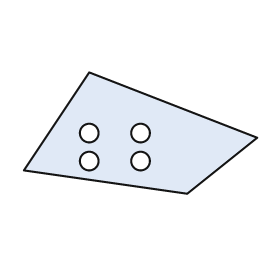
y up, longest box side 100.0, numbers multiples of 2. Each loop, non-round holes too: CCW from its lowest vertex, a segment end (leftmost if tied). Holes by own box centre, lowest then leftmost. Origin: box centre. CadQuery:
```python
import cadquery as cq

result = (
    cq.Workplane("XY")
    .moveTo(20.0, -26.0)
    .lineTo(50.0, -2.0)
    .lineTo(-22.0, 26.0)
    .lineTo(-50.0, -16.0)
    .close()
    .moveTo(-22.0, -12.0)
    .circle(4.0)
    .moveTo(0.0, -12.0)
    .circle(4.0)
    .moveTo(-22.0, 0.0)
    .circle(4.0)
    .moveTo(0.0, 0.0)
    .circle(4.0)
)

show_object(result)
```